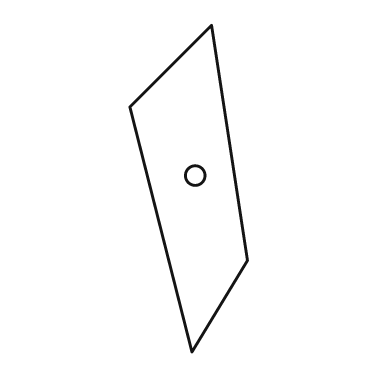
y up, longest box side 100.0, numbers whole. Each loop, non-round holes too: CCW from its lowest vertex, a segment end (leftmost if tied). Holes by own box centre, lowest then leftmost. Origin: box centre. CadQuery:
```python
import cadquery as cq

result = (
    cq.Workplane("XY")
    .moveTo(1.0, -50.0)
    .lineTo(18.0, -22.0)
    .lineTo(7.0, 50.0)
    .lineTo(-18.0, 25.0)
    .close()
    .moveTo(2.0, 4.0)
    .circle(3.0)
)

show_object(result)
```